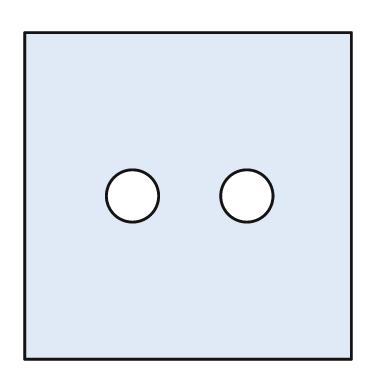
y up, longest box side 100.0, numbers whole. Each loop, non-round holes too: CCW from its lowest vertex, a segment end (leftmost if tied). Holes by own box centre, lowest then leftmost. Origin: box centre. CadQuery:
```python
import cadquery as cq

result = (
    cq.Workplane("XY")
    .moveTo(-50.0, -50.0)
    .lineTo(50.0, -50.0)
    .lineTo(50.0, 50.0)
    .lineTo(-50.0, 50.0)
    .close()
    .moveTo(-17.0, 0.0)
    .circle(8.0)
    .moveTo(18.0, 0.0)
    .circle(8.0)
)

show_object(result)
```